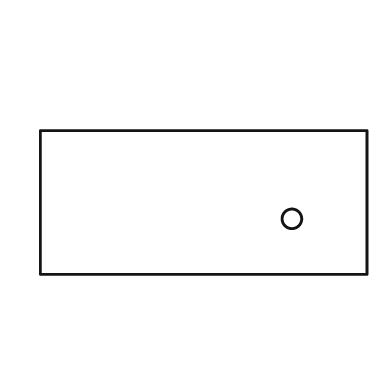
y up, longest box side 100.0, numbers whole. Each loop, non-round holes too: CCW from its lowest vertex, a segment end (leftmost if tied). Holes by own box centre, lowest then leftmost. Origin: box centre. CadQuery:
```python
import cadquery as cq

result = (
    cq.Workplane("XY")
    .moveTo(-50.0, -22.0)
    .lineTo(50.0, -22.0)
    .lineTo(50.0, 22.0)
    .lineTo(-50.0, 22.0)
    .close()
    .moveTo(27.0, -5.0)
    .circle(3.0)
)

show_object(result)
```